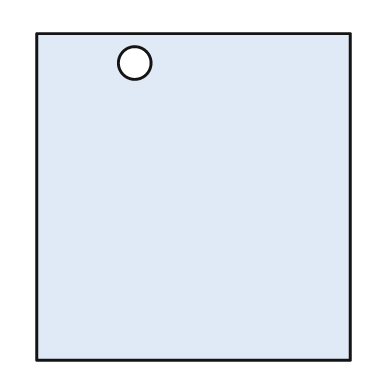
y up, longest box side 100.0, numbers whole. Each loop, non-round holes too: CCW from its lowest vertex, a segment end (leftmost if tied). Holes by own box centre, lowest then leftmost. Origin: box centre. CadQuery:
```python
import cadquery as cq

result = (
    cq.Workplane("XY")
    .moveTo(-48.0, -50.0)
    .lineTo(48.0, -50.0)
    .lineTo(48.0, 50.0)
    .lineTo(-48.0, 50.0)
    .close()
    .moveTo(-18.0, 41.0)
    .circle(5.0)
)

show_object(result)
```